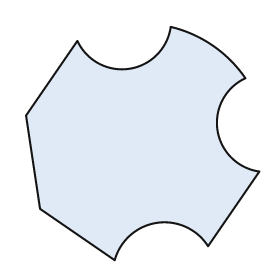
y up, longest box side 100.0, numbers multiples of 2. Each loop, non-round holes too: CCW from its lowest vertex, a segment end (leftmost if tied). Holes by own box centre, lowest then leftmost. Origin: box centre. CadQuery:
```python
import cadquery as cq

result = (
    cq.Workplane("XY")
    .moveTo(-12.0, -50.0)
    .threePointArc((6.0, -34.0), (28.0, -44.0))
    .lineTo(50.0, -12.0)
    .threePointArc((32.0, 6.0), (44.0, 28.0))
    .threePointArc((30.0, 42.0), (12.0, 50.0))
    .threePointArc((-6.0, 32.0), (-28.0, 44.0))
    .lineTo(-50.0, 12.0)
    .lineTo(-44.0, -28.0)
    .close()
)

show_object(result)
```